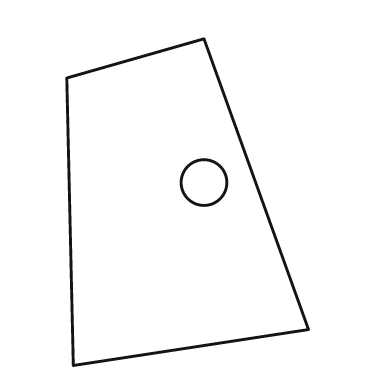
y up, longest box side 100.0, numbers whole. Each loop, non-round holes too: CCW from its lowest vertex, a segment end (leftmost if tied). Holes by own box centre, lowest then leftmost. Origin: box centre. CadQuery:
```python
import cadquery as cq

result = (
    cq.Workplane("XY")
    .moveTo(-35.0, -50.0)
    .lineTo(37.0, -39.0)
    .lineTo(5.0, 50.0)
    .lineTo(-37.0, 38.0)
    .close()
    .moveTo(5.0, 6.0)
    .circle(7.0)
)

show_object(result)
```